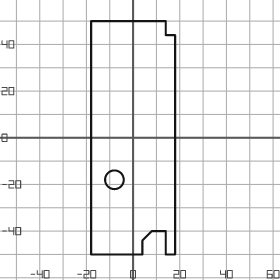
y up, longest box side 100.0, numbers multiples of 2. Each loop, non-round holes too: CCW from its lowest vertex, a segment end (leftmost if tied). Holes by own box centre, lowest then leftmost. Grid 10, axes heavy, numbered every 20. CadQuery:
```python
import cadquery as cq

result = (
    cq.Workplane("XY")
    .moveTo(-18.0, -50.0)
    .lineTo(4.0, -50.0)
    .lineTo(4.0, -44.0)
    .lineTo(8.0, -40.0)
    .lineTo(14.0, -40.0)
    .lineTo(14.0, -50.0)
    .lineTo(18.0, -50.0)
    .lineTo(18.0, 44.0)
    .lineTo(14.0, 44.0)
    .lineTo(14.0, 50.0)
    .lineTo(-18.0, 50.0)
    .close()
    .moveTo(-8.0, -18.0)
    .circle(4.0)
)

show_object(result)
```